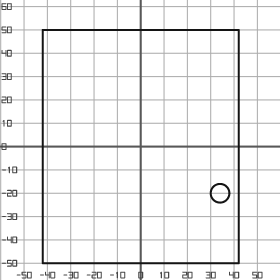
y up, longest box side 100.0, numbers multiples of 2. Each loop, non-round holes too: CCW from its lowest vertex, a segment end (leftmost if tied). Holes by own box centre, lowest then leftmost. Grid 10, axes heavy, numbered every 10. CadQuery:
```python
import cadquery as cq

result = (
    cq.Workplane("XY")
    .moveTo(-42.0, -50.0)
    .lineTo(42.0, -50.0)
    .lineTo(42.0, 50.0)
    .lineTo(-42.0, 50.0)
    .close()
    .moveTo(34.0, -20.0)
    .circle(4.0)
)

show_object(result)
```